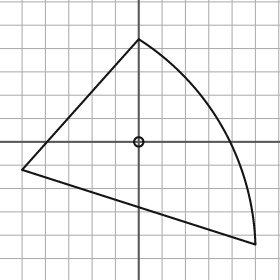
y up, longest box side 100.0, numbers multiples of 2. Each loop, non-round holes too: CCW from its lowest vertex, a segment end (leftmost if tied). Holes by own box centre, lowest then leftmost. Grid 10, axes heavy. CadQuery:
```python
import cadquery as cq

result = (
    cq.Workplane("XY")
    .moveTo(50.0, -44.0)
    .threePointArc((36.0, 6.0), (0.0, 44.0))
    .lineTo(-50.0, -12.0)
    .close()
    .moveTo(0.0, 0.0)
    .circle(2.0)
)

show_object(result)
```